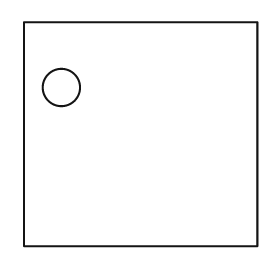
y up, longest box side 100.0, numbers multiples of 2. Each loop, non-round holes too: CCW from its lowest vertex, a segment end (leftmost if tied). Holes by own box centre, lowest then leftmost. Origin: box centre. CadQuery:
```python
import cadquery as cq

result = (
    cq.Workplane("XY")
    .moveTo(-50.0, -48.0)
    .lineTo(50.0, -48.0)
    .lineTo(50.0, 48.0)
    .lineTo(-50.0, 48.0)
    .close()
    .moveTo(-34.0, 20.0)
    .circle(8.0)
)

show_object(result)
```